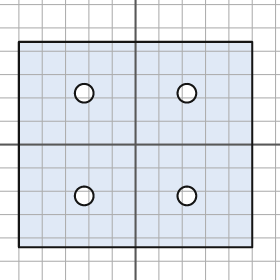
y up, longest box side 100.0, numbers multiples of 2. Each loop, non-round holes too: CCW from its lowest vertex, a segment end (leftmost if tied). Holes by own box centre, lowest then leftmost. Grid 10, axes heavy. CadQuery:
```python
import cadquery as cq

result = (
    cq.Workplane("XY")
    .moveTo(-50.0, -44.0)
    .lineTo(50.0, -44.0)
    .lineTo(50.0, 44.0)
    .lineTo(-50.0, 44.0)
    .close()
    .moveTo(-22.0, -22.0)
    .circle(4.0)
    .moveTo(22.0, -22.0)
    .circle(4.0)
    .moveTo(-22.0, 22.0)
    .circle(4.0)
    .moveTo(22.0, 22.0)
    .circle(4.0)
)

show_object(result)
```